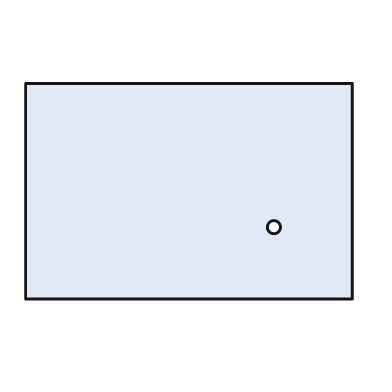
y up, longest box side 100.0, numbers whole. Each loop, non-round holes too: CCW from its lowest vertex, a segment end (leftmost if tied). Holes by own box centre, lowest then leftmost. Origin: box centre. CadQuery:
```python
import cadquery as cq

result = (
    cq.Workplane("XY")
    .moveTo(-50.0, -33.0)
    .lineTo(50.0, -33.0)
    .lineTo(50.0, 33.0)
    .lineTo(-50.0, 33.0)
    .close()
    .moveTo(26.0, -11.0)
    .circle(2.0)
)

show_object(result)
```